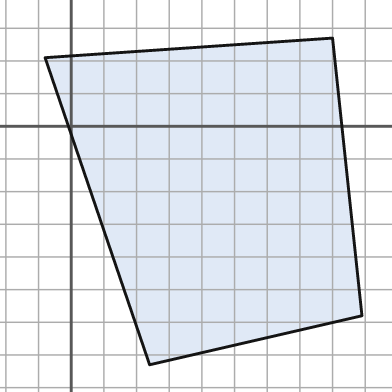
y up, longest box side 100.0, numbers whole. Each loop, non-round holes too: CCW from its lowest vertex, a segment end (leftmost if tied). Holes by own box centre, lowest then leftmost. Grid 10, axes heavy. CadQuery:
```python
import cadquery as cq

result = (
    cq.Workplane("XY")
    .moveTo(24.0, -73.0)
    .lineTo(89.0, -58.0)
    .lineTo(80.0, 27.0)
    .lineTo(-8.0, 21.0)
    .close()
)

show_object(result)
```